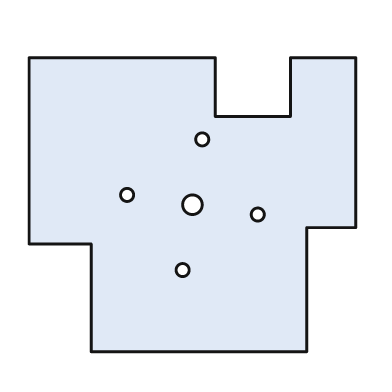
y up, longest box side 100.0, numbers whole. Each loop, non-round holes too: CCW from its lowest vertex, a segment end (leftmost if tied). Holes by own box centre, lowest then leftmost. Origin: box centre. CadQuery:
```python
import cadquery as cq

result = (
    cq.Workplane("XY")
    .moveTo(-31.0, -45.0)
    .lineTo(35.0, -45.0)
    .lineTo(35.0, -7.0)
    .lineTo(50.0, -7.0)
    .lineTo(50.0, 45.0)
    .lineTo(30.0, 45.0)
    .lineTo(30.0, 27.0)
    .lineTo(7.0, 27.0)
    .lineTo(7.0, 45.0)
    .lineTo(-50.0, 45.0)
    .lineTo(-50.0, -12.0)
    .lineTo(-31.0, -12.0)
    .close()
    .moveTo(-3.0, -20.0)
    .circle(2.0)
    .moveTo(20.0, -3.0)
    .circle(2.0)
    .moveTo(0.0, 0.0)
    .circle(3.0)
    .moveTo(-20.0, 3.0)
    .circle(2.0)
    .moveTo(3.0, 20.0)
    .circle(2.0)
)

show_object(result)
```